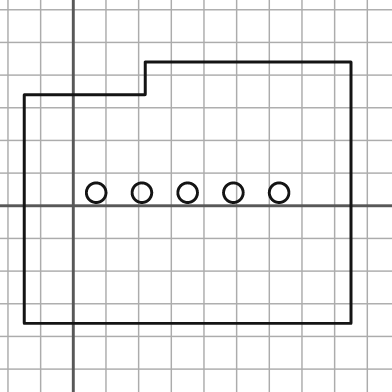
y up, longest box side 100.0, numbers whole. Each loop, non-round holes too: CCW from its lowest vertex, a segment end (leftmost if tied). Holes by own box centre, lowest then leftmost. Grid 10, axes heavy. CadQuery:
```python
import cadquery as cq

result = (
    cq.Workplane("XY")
    .moveTo(-15.0, -36.0)
    .lineTo(85.0, -36.0)
    .lineTo(85.0, 44.0)
    .lineTo(22.0, 44.0)
    .lineTo(22.0, 34.0)
    .lineTo(-15.0, 34.0)
    .close()
    .moveTo(7.0, 4.0)
    .circle(3.0)
    .moveTo(21.0, 4.0)
    .circle(3.0)
    .moveTo(35.0, 4.0)
    .circle(3.0)
    .moveTo(49.0, 4.0)
    .circle(3.0)
    .moveTo(63.0, 4.0)
    .circle(3.0)
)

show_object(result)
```